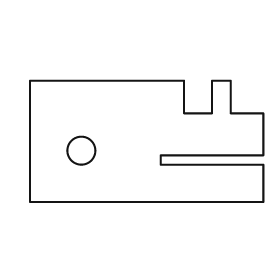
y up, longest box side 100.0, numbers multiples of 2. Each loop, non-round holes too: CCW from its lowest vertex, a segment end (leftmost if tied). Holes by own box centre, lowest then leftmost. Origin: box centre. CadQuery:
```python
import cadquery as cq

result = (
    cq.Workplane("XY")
    .moveTo(-50.0, -26.0)
    .lineTo(50.0, -26.0)
    .lineTo(50.0, -10.0)
    .lineTo(6.0, -10.0)
    .lineTo(6.0, -6.0)
    .lineTo(50.0, -6.0)
    .lineTo(50.0, 12.0)
    .lineTo(36.0, 12.0)
    .lineTo(36.0, 26.0)
    .lineTo(28.0, 26.0)
    .lineTo(28.0, 12.0)
    .lineTo(16.0, 12.0)
    .lineTo(16.0, 26.0)
    .lineTo(-50.0, 26.0)
    .close()
    .moveTo(-28.0, -4.0)
    .circle(6.0)
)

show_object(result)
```